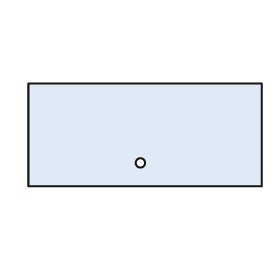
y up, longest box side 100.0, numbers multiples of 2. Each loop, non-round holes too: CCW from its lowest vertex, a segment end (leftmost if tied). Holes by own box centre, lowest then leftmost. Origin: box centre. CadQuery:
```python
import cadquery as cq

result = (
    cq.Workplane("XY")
    .moveTo(-50.0, -22.0)
    .lineTo(50.0, -22.0)
    .lineTo(50.0, 22.0)
    .lineTo(-50.0, 22.0)
    .close()
    .moveTo(-2.0, -12.0)
    .circle(2.0)
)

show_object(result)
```